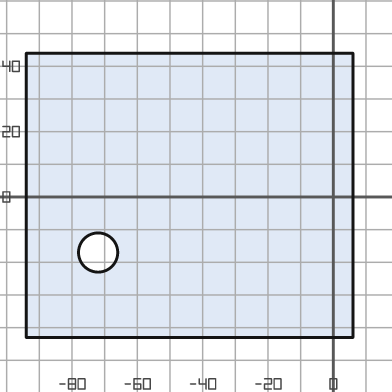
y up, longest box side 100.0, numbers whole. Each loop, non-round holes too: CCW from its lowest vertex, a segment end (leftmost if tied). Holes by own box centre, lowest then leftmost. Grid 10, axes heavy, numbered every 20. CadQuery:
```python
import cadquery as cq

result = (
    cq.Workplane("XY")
    .moveTo(-94.0, -43.0)
    .lineTo(6.0, -43.0)
    .lineTo(6.0, 44.0)
    .lineTo(-94.0, 44.0)
    .close()
    .moveTo(-72.0, -17.0)
    .circle(6.0)
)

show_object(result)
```